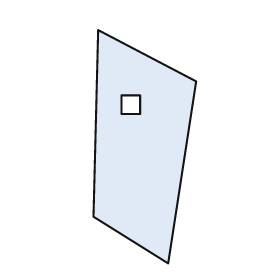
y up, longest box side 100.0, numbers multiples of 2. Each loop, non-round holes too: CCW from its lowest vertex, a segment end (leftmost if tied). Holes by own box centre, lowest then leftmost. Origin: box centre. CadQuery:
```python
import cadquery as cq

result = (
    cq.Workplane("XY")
    .moveTo(10.0, -50.0)
    .lineTo(22.0, 28.0)
    .lineTo(-20.0, 50.0)
    .lineTo(-22.0, -30.0)
    .close()
    .moveTo(-10.0, 14.0)
    .lineTo(-2.0, 14.0)
    .lineTo(-2.0, 22.0)
    .lineTo(-10.0, 22.0)
    .close()
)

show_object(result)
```